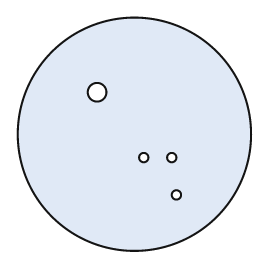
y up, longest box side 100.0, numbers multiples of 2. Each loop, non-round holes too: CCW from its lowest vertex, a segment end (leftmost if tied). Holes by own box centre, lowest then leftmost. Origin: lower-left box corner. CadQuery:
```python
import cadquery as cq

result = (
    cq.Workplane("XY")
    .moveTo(50.0, 50.0)
    .circle(50.0)
    .moveTo(68.0, 24.0)
    .circle(2.0)
    .moveTo(54.0, 40.0)
    .circle(2.0)
    .moveTo(66.0, 40.0)
    .circle(2.0)
    .moveTo(34.0, 68.0)
    .circle(4.0)
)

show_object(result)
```